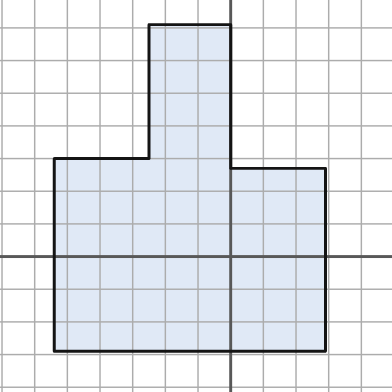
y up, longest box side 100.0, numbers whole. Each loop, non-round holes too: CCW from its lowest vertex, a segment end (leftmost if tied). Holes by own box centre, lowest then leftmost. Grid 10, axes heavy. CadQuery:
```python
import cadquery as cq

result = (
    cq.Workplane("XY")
    .moveTo(-54.0, -29.0)
    .lineTo(29.0, -29.0)
    .lineTo(29.0, 27.0)
    .lineTo(0.0, 27.0)
    .lineTo(0.0, 71.0)
    .lineTo(-25.0, 71.0)
    .lineTo(-25.0, 30.0)
    .lineTo(-54.0, 30.0)
    .close()
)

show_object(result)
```